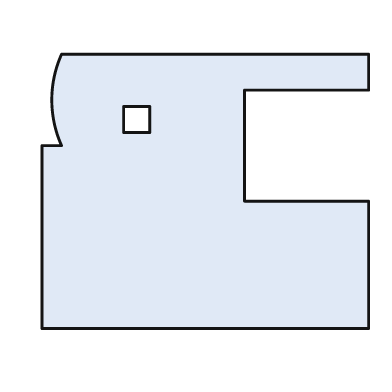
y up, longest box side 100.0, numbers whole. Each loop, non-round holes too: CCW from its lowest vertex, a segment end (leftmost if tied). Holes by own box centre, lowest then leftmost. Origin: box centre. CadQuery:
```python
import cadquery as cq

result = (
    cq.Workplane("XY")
    .moveTo(-50.0, -42.0)
    .lineTo(50.0, -42.0)
    .lineTo(50.0, -3.0)
    .lineTo(12.0, -3.0)
    .lineTo(12.0, 31.0)
    .lineTo(50.0, 31.0)
    .lineTo(50.0, 42.0)
    .lineTo(-44.0, 42.0)
    .threePointArc((-47.0, 28.0), (-44.0, 14.0))
    .lineTo(-50.0, 14.0)
    .close()
    .moveTo(-25.0, 18.0)
    .lineTo(-17.0, 18.0)
    .lineTo(-17.0, 26.0)
    .lineTo(-25.0, 26.0)
    .close()
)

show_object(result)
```